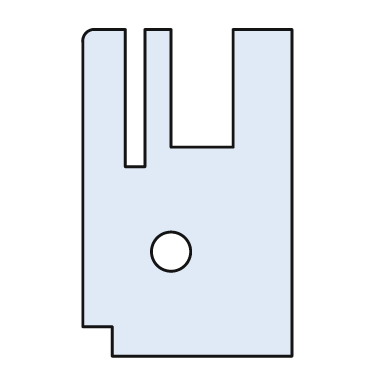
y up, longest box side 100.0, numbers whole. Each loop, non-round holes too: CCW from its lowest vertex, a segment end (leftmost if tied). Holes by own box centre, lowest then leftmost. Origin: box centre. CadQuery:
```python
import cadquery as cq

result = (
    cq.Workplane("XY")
    .moveTo(-23.0, -50.0)
    .lineTo(32.0, -50.0)
    .lineTo(32.0, 50.0)
    .lineTo(14.0, 50.0)
    .lineTo(14.0, 14.0)
    .lineTo(-5.0, 14.0)
    .lineTo(-5.0, 50.0)
    .lineTo(-13.0, 50.0)
    .lineTo(-13.0, 8.0)
    .lineTo(-19.0, 8.0)
    .lineTo(-19.0, 50.0)
    .lineTo(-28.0, 50.0)
    .threePointArc((-31.0, 49.0), (-32.0, 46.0))
    .lineTo(-32.0, -41.0)
    .lineTo(-23.0, -41.0)
    .close()
    .moveTo(-5.0, -18.0)
    .circle(6.0)
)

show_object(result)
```